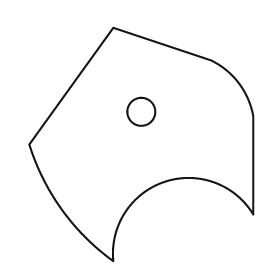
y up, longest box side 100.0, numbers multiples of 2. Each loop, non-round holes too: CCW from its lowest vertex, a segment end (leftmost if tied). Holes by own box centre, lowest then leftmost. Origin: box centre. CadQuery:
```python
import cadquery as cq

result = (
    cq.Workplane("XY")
    .moveTo(-12.0, -50.0)
    .threePointArc((10.0, -16.0), (48.0, -30.0))
    .lineTo(48.0, 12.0)
    .threePointArc((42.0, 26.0), (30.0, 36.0))
    .lineTo(-12.0, 50.0)
    .lineTo(-48.0, 0.0)
    .threePointArc((-34.0, -28.0), (-12.0, -50.0))
    .close()
    .moveTo(0.0, 14.0)
    .circle(6.0)
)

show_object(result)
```